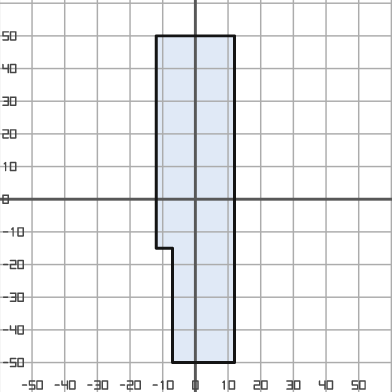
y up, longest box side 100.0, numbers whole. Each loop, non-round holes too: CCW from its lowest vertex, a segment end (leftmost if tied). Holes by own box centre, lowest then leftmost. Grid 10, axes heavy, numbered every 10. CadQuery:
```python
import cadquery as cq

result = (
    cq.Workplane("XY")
    .moveTo(-7.0, -50.0)
    .lineTo(12.0, -50.0)
    .lineTo(12.0, 50.0)
    .lineTo(-12.0, 50.0)
    .lineTo(-12.0, -15.0)
    .lineTo(-7.0, -15.0)
    .close()
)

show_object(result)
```